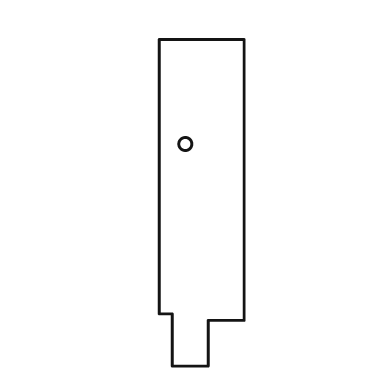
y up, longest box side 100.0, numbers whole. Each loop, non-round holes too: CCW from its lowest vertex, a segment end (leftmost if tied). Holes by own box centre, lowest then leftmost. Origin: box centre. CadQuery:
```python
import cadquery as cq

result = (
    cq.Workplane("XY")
    .moveTo(-9.0, -50.0)
    .lineTo(2.0, -50.0)
    .lineTo(2.0, -36.0)
    .lineTo(13.0, -36.0)
    .lineTo(13.0, 50.0)
    .lineTo(-13.0, 50.0)
    .lineTo(-13.0, -34.0)
    .lineTo(-9.0, -34.0)
    .close()
    .moveTo(-5.0, 18.0)
    .circle(2.0)
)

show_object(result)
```